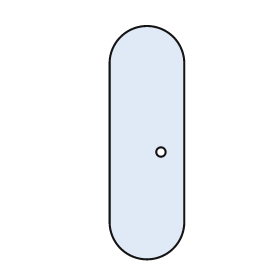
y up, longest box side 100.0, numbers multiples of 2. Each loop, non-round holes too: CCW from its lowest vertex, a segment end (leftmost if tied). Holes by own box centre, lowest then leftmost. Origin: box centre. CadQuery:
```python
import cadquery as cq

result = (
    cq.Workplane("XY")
    .moveTo(-16.0, -34.0)
    .threePointArc((0.0, -50.0), (16.0, -34.0))
    .lineTo(16.0, 34.0)
    .threePointArc((0.0, 50.0), (-16.0, 34.0))
    .close()
    .moveTo(6.0, -4.0)
    .circle(2.0)
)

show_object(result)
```